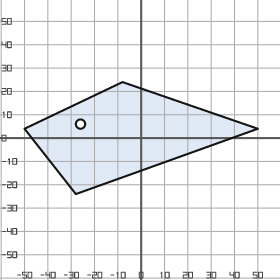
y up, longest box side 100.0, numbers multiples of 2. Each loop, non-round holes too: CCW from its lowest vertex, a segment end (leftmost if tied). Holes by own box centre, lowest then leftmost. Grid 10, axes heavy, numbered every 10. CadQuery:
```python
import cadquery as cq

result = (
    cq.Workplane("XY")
    .moveTo(-28.0, -24.0)
    .lineTo(50.0, 4.0)
    .lineTo(-8.0, 24.0)
    .lineTo(-50.0, 4.0)
    .close()
    .moveTo(-26.0, 6.0)
    .circle(2.0)
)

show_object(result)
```